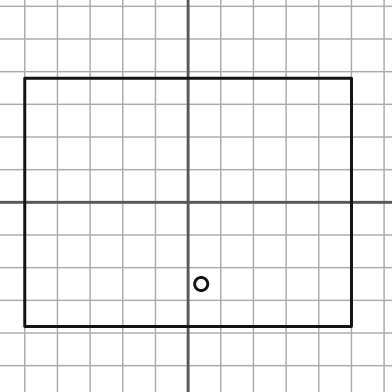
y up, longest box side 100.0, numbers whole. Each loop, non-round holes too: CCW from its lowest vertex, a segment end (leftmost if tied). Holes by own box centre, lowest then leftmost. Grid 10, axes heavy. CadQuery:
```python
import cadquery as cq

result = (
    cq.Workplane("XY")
    .moveTo(-50.0, -38.0)
    .lineTo(50.0, -38.0)
    .lineTo(50.0, 38.0)
    .lineTo(-50.0, 38.0)
    .close()
    .moveTo(4.0, -25.0)
    .circle(2.0)
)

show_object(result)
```